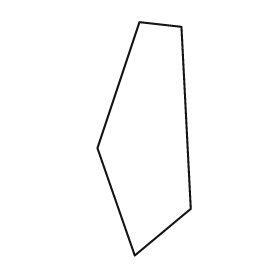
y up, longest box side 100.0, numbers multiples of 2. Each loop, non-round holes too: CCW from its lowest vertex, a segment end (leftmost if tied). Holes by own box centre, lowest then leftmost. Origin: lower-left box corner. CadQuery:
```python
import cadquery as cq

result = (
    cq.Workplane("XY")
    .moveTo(16.0, 0.0)
    .lineTo(40.0, 20.0)
    .lineTo(36.0, 98.0)
    .lineTo(18.0, 100.0)
    .lineTo(0.0, 46.0)
    .close()
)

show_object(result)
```